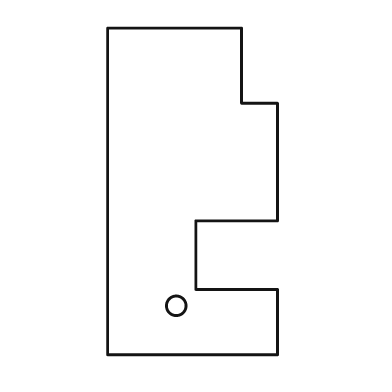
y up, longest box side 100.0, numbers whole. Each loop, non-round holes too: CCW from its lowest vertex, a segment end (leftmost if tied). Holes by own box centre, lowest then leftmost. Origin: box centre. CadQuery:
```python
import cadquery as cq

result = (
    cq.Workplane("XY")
    .moveTo(-26.0, -50.0)
    .lineTo(26.0, -50.0)
    .lineTo(26.0, -30.0)
    .lineTo(1.0, -30.0)
    .lineTo(1.0, -9.0)
    .lineTo(26.0, -9.0)
    .lineTo(26.0, 27.0)
    .lineTo(15.0, 27.0)
    .lineTo(15.0, 50.0)
    .lineTo(-26.0, 50.0)
    .close()
    .moveTo(-5.0, -35.0)
    .circle(3.0)
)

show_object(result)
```